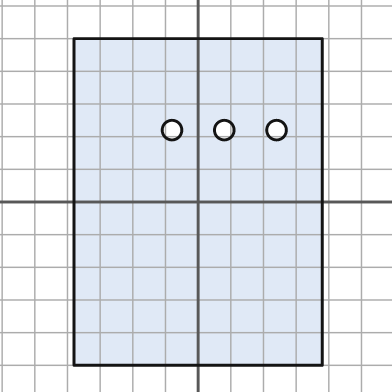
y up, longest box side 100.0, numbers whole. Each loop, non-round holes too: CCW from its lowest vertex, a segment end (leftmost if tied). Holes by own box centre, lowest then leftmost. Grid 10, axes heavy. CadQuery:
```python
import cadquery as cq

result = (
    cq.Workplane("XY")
    .moveTo(-38.0, -50.0)
    .lineTo(38.0, -50.0)
    .lineTo(38.0, 50.0)
    .lineTo(-38.0, 50.0)
    .close()
    .moveTo(-8.0, 22.0)
    .circle(3.0)
    .moveTo(8.0, 22.0)
    .circle(3.0)
    .moveTo(24.0, 22.0)
    .circle(3.0)
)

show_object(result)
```